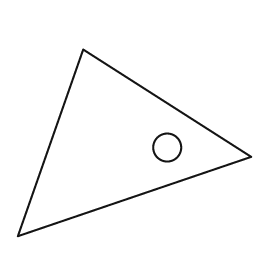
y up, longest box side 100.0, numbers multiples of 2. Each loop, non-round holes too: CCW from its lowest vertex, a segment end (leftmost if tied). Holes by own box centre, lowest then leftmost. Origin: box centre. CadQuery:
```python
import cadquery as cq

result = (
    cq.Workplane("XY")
    .moveTo(-50.0, -40.0)
    .lineTo(50.0, -6.0)
    .lineTo(-22.0, 40.0)
    .close()
    .moveTo(14.0, -2.0)
    .circle(6.0)
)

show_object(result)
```